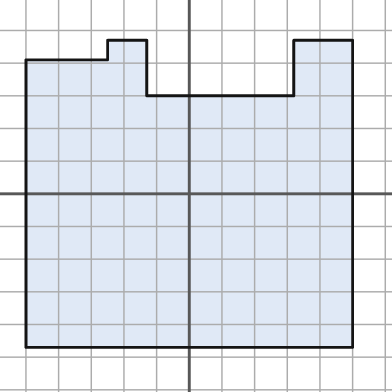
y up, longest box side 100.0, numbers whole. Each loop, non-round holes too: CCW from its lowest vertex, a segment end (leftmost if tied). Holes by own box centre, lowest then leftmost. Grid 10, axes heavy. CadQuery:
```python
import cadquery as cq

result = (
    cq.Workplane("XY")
    .moveTo(-50.0, -47.0)
    .lineTo(50.0, -47.0)
    .lineTo(50.0, 47.0)
    .lineTo(32.0, 47.0)
    .lineTo(32.0, 30.0)
    .lineTo(-13.0, 30.0)
    .lineTo(-13.0, 47.0)
    .lineTo(-25.0, 47.0)
    .lineTo(-25.0, 41.0)
    .lineTo(-50.0, 41.0)
    .close()
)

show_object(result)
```